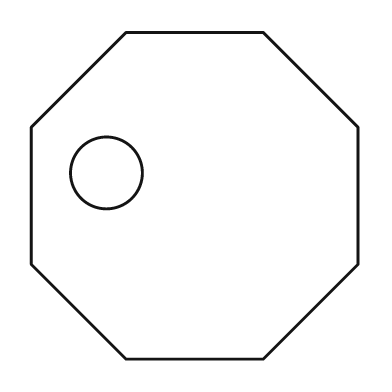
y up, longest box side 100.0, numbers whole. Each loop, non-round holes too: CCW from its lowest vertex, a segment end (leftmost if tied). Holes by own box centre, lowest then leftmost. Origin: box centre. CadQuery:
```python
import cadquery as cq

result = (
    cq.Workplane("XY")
    .moveTo(-21.0, -50.0)
    .lineTo(21.0, -50.0)
    .lineTo(50.0, -21.0)
    .lineTo(50.0, 21.0)
    .lineTo(21.0, 50.0)
    .lineTo(-21.0, 50.0)
    .lineTo(-50.0, 21.0)
    .lineTo(-50.0, -21.0)
    .close()
    .moveTo(-27.0, 7.0)
    .circle(11.0)
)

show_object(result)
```